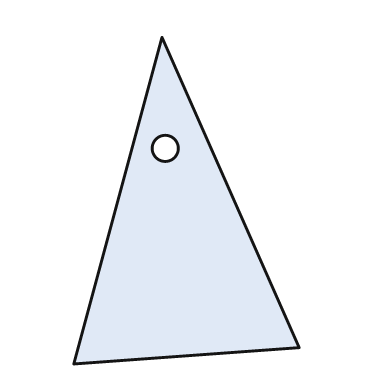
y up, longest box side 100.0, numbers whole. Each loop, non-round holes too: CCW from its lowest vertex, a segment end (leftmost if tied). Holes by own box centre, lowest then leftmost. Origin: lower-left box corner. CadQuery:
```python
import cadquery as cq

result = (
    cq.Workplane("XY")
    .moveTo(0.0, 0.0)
    .lineTo(69.0, 5.0)
    .lineTo(27.0, 100.0)
    .close()
    .moveTo(28.0, 66.0)
    .circle(4.0)
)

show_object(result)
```